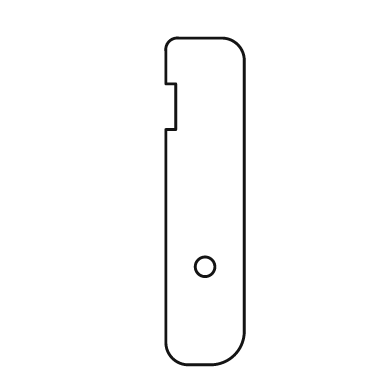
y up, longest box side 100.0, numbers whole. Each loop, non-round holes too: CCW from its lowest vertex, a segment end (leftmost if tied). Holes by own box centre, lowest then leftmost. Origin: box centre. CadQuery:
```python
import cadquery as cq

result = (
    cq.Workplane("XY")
    .moveTo(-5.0, -50.0)
    .lineTo(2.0, -50.0)
    .threePointArc((9.0, -47.0), (12.0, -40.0))
    .lineTo(12.0, 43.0)
    .threePointArc((10.0, 48.0), (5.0, 50.0))
    .lineTo(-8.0, 50.0)
    .threePointArc((-11.0, 49.0), (-12.0, 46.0))
    .lineTo(-12.0, 36.0)
    .lineTo(-9.0, 36.0)
    .lineTo(-9.0, 22.0)
    .lineTo(-12.0, 22.0)
    .lineTo(-12.0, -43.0)
    .threePointArc((-10.0, -48.0), (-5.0, -50.0))
    .close()
    .moveTo(0.0, -20.0)
    .circle(3.0)
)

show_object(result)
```